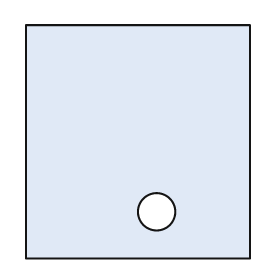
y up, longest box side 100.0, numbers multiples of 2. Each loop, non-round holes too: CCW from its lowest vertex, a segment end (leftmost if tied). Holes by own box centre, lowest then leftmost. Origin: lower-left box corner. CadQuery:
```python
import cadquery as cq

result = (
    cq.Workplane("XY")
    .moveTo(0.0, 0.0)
    .lineTo(96.0, 0.0)
    .lineTo(96.0, 100.0)
    .lineTo(0.0, 100.0)
    .close()
    .moveTo(56.0, 20.0)
    .circle(8.0)
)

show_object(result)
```